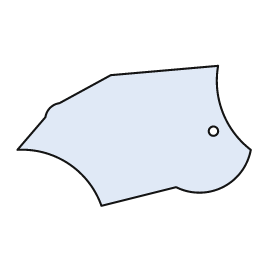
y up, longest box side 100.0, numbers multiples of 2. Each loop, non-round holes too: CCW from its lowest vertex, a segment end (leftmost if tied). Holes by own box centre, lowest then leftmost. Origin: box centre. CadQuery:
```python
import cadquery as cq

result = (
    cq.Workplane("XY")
    .moveTo(-14.0, -30.0)
    .lineTo(18.0, -22.0)
    .threePointArc((38.0, -22.0), (50.0, -6.0))
    .threePointArc((38.0, 10.0), (36.0, 30.0))
    .lineTo(-10.0, 26.0)
    .lineTo(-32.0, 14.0)
    .threePointArc((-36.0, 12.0), (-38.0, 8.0))
    .lineTo(-50.0, -6.0)
    .threePointArc((-28.0, -12.0), (-14.0, -30.0))
    .close()
    .moveTo(34.0, 2.0)
    .circle(2.0)
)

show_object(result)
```